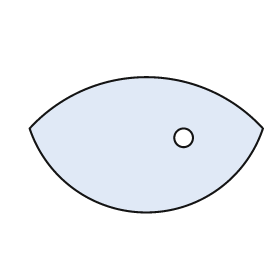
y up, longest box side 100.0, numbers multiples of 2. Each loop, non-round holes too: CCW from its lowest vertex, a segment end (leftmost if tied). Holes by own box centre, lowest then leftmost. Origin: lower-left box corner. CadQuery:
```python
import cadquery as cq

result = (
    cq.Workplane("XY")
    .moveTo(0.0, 36.0)
    .threePointArc((50.0, 0.0), (100.0, 36.0))
    .threePointArc((50.0, 58.0), (0.0, 36.0))
    .close()
    .moveTo(66.0, 32.0)
    .circle(4.0)
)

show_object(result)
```